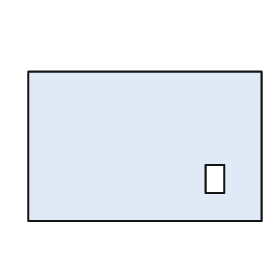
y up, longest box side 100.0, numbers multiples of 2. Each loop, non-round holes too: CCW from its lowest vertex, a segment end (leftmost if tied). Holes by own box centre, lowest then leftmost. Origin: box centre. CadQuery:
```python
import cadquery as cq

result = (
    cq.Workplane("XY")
    .moveTo(-50.0, -32.0)
    .lineTo(50.0, -32.0)
    .lineTo(50.0, 32.0)
    .lineTo(-50.0, 32.0)
    .close()
    .moveTo(26.0, -20.0)
    .lineTo(34.0, -20.0)
    .lineTo(34.0, -8.0)
    .lineTo(26.0, -8.0)
    .close()
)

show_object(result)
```